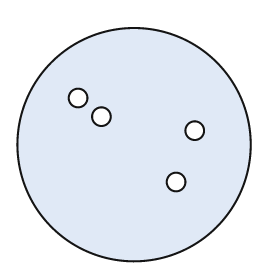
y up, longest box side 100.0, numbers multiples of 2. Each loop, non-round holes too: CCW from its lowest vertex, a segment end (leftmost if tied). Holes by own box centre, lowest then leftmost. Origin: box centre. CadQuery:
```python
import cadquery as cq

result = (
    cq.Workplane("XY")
    .moveTo(0.0, 0.0)
    .circle(50.0)
    .moveTo(18.0, -16.0)
    .circle(4.0)
    .moveTo(26.0, 6.0)
    .circle(4.0)
    .moveTo(-14.0, 12.0)
    .circle(4.0)
    .moveTo(-24.0, 20.0)
    .circle(4.0)
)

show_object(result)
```